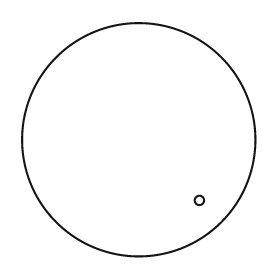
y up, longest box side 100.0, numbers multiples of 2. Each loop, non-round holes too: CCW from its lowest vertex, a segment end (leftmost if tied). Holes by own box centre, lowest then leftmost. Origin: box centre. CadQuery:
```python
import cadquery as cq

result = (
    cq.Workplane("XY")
    .moveTo(0.0, 0.0)
    .circle(50.0)
    .moveTo(26.0, -26.0)
    .circle(2.0)
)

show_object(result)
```